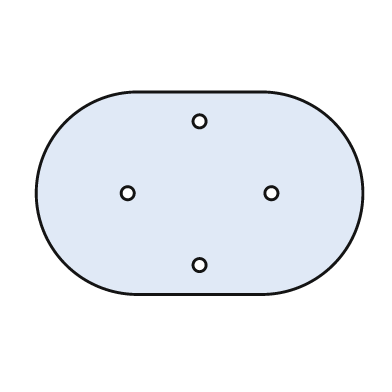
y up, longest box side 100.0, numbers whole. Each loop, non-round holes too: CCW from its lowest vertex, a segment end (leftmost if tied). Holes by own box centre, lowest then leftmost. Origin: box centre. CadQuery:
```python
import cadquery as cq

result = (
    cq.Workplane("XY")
    .moveTo(-19.0, -31.0)
    .lineTo(19.0, -31.0)
    .threePointArc((50.0, 0.0), (19.0, 31.0))
    .lineTo(-19.0, 31.0)
    .threePointArc((-50.0, 0.0), (-19.0, -31.0))
    .close()
    .moveTo(0.0, -22.0)
    .circle(2.0)
    .moveTo(-22.0, 0.0)
    .circle(2.0)
    .moveTo(22.0, 0.0)
    .circle(2.0)
    .moveTo(0.0, 22.0)
    .circle(2.0)
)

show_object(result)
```